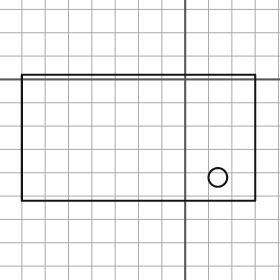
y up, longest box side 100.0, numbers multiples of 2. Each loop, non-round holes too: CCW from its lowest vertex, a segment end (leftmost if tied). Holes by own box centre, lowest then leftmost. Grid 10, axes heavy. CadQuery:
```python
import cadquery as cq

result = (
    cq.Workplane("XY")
    .moveTo(-70.0, -52.0)
    .lineTo(30.0, -52.0)
    .lineTo(30.0, 2.0)
    .lineTo(-70.0, 2.0)
    .close()
    .moveTo(14.0, -42.0)
    .circle(4.0)
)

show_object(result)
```